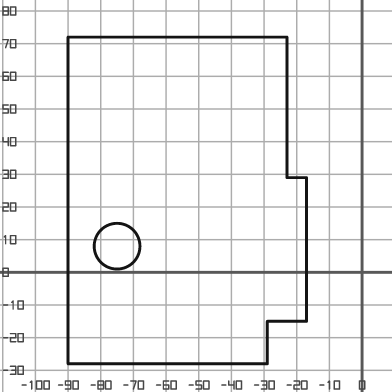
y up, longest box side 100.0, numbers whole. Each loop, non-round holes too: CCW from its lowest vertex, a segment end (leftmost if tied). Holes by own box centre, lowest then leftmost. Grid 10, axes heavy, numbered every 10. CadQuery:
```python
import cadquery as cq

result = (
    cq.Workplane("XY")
    .moveTo(-90.0, -28.0)
    .lineTo(-29.0, -28.0)
    .lineTo(-29.0, -15.0)
    .lineTo(-17.0, -15.0)
    .lineTo(-17.0, 29.0)
    .lineTo(-23.0, 29.0)
    .lineTo(-23.0, 72.0)
    .lineTo(-90.0, 72.0)
    .close()
    .moveTo(-75.0, 8.0)
    .circle(7.0)
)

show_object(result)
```